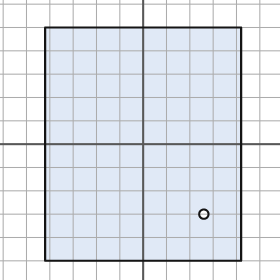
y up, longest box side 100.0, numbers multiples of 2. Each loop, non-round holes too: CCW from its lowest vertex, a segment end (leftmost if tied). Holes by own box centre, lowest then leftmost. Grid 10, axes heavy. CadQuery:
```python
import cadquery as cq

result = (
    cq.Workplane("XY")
    .moveTo(-42.0, -50.0)
    .lineTo(42.0, -50.0)
    .lineTo(42.0, 50.0)
    .lineTo(-42.0, 50.0)
    .close()
    .moveTo(26.0, -30.0)
    .circle(2.0)
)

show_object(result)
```